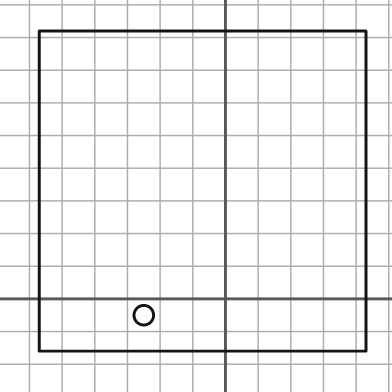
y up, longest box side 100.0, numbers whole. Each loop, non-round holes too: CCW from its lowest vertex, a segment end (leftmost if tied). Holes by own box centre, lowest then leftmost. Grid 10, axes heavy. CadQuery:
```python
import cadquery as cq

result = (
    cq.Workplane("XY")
    .moveTo(-57.0, -16.0)
    .lineTo(43.0, -16.0)
    .lineTo(43.0, 82.0)
    .lineTo(-57.0, 82.0)
    .close()
    .moveTo(-25.0, -5.0)
    .circle(3.0)
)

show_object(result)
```